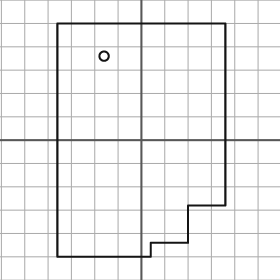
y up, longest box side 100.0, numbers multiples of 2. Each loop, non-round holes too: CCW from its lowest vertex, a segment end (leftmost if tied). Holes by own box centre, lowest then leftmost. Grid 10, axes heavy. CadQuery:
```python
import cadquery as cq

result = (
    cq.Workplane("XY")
    .moveTo(-36.0, -50.0)
    .lineTo(4.0, -50.0)
    .lineTo(4.0, -44.0)
    .lineTo(20.0, -44.0)
    .lineTo(20.0, -28.0)
    .lineTo(36.0, -28.0)
    .lineTo(36.0, 50.0)
    .lineTo(-36.0, 50.0)
    .close()
    .moveTo(-16.0, 36.0)
    .circle(2.0)
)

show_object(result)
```